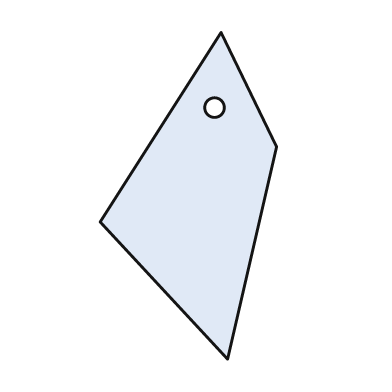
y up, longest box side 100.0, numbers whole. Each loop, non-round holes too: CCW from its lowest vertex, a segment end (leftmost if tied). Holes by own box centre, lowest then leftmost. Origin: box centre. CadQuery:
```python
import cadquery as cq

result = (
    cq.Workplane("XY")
    .moveTo(12.0, -50.0)
    .lineTo(27.0, 15.0)
    .lineTo(10.0, 50.0)
    .lineTo(-27.0, -8.0)
    .close()
    .moveTo(8.0, 27.0)
    .circle(3.0)
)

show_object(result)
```